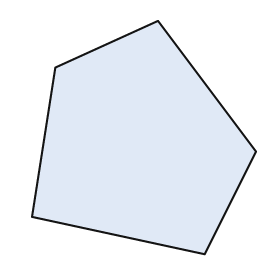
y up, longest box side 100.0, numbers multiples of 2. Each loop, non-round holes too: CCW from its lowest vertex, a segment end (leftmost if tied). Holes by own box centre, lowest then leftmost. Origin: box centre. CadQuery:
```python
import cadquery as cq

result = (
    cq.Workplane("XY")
    .moveTo(26.0, -50.0)
    .lineTo(48.0, -6.0)
    .lineTo(6.0, 50.0)
    .lineTo(-38.0, 30.0)
    .lineTo(-48.0, -34.0)
    .close()
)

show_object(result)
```